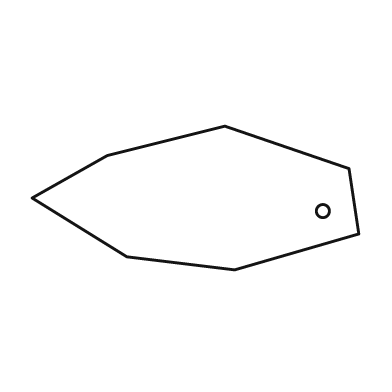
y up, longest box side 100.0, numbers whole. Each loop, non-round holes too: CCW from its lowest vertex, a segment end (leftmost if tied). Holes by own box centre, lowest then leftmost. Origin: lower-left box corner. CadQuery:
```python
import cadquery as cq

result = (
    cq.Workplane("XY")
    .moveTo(62.0, 0.0)
    .lineTo(100.0, 11.0)
    .lineTo(97.0, 31.0)
    .lineTo(59.0, 44.0)
    .lineTo(23.0, 35.0)
    .lineTo(0.0, 22.0)
    .lineTo(29.0, 4.0)
    .close()
    .moveTo(89.0, 18.0)
    .circle(2.0)
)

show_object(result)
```